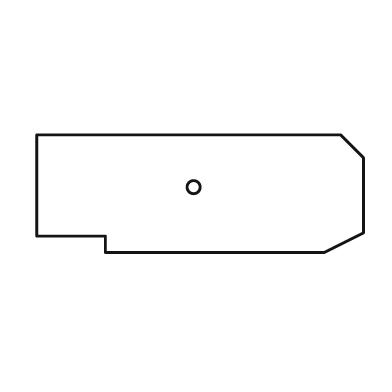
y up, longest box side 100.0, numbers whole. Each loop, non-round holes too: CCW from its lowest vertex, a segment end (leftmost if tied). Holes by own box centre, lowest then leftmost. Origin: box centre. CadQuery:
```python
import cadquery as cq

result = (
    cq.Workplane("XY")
    .moveTo(-29.0, -18.0)
    .lineTo(38.0, -18.0)
    .lineTo(50.0, -12.0)
    .lineTo(50.0, 11.0)
    .lineTo(43.0, 18.0)
    .lineTo(-50.0, 18.0)
    .lineTo(-50.0, -13.0)
    .lineTo(-29.0, -13.0)
    .close()
    .moveTo(-2.0, 2.0)
    .circle(2.0)
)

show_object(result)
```